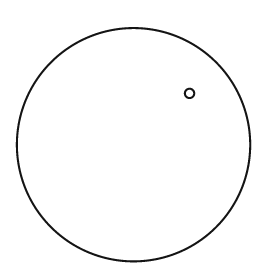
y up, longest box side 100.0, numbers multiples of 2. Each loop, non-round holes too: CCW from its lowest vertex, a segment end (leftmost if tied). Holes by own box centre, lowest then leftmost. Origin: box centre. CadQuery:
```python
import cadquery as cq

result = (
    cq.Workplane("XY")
    .moveTo(0.0, 0.0)
    .circle(50.0)
    .moveTo(24.0, 22.0)
    .circle(2.0)
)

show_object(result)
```